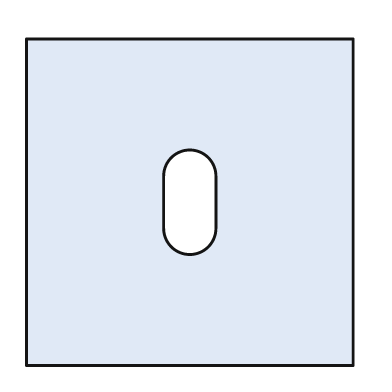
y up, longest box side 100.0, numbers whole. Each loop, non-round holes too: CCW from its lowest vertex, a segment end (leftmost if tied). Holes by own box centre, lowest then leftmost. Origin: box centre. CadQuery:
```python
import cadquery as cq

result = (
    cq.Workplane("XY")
    .moveTo(-50.0, -50.0)
    .lineTo(50.0, -50.0)
    .lineTo(50.0, 50.0)
    .lineTo(-50.0, 50.0)
    .close()
    .moveTo(-8.0, -8.0)
    .threePointArc((0.0, -16.0), (8.0, -8.0))
    .lineTo(8.0, 8.0)
    .threePointArc((0.0, 16.0), (-8.0, 8.0))
    .close()
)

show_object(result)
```